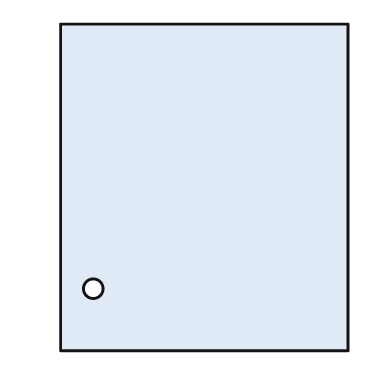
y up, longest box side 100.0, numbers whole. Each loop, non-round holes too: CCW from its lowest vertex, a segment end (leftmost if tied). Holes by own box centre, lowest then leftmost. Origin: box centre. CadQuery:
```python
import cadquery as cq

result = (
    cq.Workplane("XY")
    .moveTo(-44.0, -50.0)
    .lineTo(44.0, -50.0)
    .lineTo(44.0, 50.0)
    .lineTo(-44.0, 50.0)
    .close()
    .moveTo(-34.0, -31.0)
    .circle(3.0)
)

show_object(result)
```